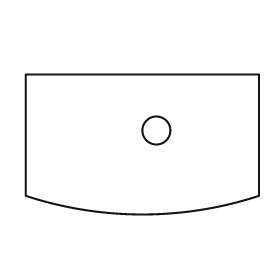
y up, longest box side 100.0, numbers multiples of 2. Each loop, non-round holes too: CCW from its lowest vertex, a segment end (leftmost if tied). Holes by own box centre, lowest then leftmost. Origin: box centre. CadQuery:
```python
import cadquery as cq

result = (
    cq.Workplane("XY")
    .moveTo(-50.0, -22.0)
    .threePointArc((0.0, -30.0), (50.0, -22.0))
    .lineTo(50.0, 30.0)
    .lineTo(-50.0, 30.0)
    .close()
    .moveTo(6.0, 6.0)
    .circle(6.0)
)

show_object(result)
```